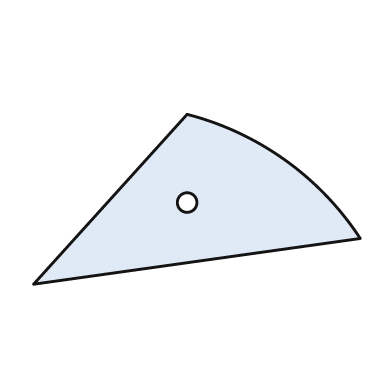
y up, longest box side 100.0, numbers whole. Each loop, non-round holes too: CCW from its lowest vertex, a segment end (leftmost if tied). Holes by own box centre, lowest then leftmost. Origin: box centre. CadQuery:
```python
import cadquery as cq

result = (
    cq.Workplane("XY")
    .moveTo(-50.0, -26.0)
    .lineTo(50.0, -12.0)
    .threePointArc((27.0, 12.0), (-3.0, 26.0))
    .close()
    .moveTo(-3.0, -1.0)
    .circle(3.0)
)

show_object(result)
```